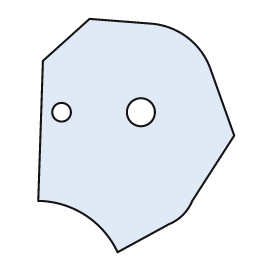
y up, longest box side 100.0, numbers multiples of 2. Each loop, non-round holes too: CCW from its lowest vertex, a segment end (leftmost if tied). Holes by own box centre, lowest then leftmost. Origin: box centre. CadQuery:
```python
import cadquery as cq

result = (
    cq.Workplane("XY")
    .moveTo(-8.0, -50.0)
    .lineTo(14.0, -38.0)
    .threePointArc((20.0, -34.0), (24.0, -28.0))
    .lineTo(42.0, 0.0)
    .lineTo(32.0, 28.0)
    .threePointArc((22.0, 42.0), (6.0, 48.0))
    .lineTo(-20.0, 50.0)
    .lineTo(-40.0, 32.0)
    .lineTo(-42.0, -28.0)
    .threePointArc((-22.0, -34.0), (-8.0, -50.0))
    .close()
    .moveTo(-32.0, 10.0)
    .circle(4.0)
    .moveTo(2.0, 10.0)
    .circle(6.0)
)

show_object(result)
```